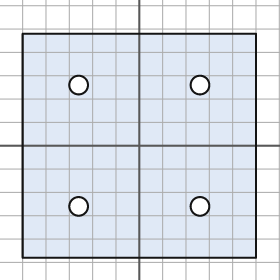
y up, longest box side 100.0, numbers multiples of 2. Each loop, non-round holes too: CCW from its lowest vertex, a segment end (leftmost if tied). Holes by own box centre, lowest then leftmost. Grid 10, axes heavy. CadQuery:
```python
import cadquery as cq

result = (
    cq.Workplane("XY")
    .moveTo(-50.0, -48.0)
    .lineTo(50.0, -48.0)
    .lineTo(50.0, 48.0)
    .lineTo(-50.0, 48.0)
    .close()
    .moveTo(-26.0, -26.0)
    .circle(4.0)
    .moveTo(26.0, -26.0)
    .circle(4.0)
    .moveTo(-26.0, 26.0)
    .circle(4.0)
    .moveTo(26.0, 26.0)
    .circle(4.0)
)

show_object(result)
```